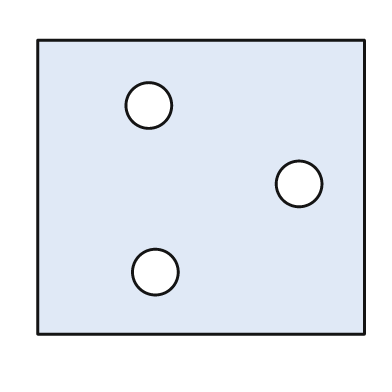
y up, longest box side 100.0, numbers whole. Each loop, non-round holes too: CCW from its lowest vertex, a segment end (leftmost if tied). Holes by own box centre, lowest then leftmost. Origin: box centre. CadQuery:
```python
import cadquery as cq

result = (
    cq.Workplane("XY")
    .moveTo(-50.0, -45.0)
    .lineTo(50.0, -45.0)
    .lineTo(50.0, 45.0)
    .lineTo(-50.0, 45.0)
    .close()
    .moveTo(-14.0, -26.0)
    .circle(7.0)
    .moveTo(30.0, 1.0)
    .circle(7.0)
    .moveTo(-16.0, 25.0)
    .circle(7.0)
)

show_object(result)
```